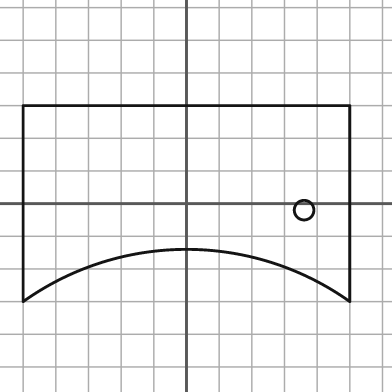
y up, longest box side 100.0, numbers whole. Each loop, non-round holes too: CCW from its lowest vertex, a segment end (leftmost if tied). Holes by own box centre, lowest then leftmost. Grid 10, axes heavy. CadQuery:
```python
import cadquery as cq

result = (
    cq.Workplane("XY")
    .moveTo(-50.0, -30.0)
    .threePointArc((0.0, -14.0), (50.0, -30.0))
    .lineTo(50.0, 30.0)
    .lineTo(-50.0, 30.0)
    .close()
    .moveTo(36.0, -2.0)
    .circle(3.0)
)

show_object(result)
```